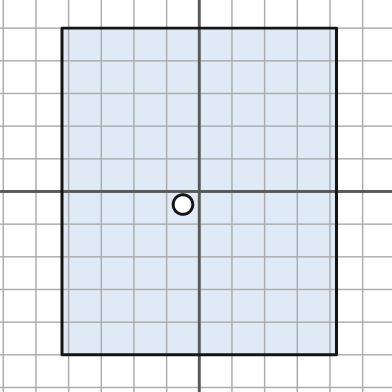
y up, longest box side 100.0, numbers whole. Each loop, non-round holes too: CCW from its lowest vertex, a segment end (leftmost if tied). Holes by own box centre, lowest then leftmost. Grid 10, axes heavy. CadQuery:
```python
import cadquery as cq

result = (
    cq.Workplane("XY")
    .moveTo(-42.0, -50.0)
    .lineTo(42.0, -50.0)
    .lineTo(42.0, 50.0)
    .lineTo(-42.0, 50.0)
    .close()
    .moveTo(-5.0, -4.0)
    .circle(3.0)
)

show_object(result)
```